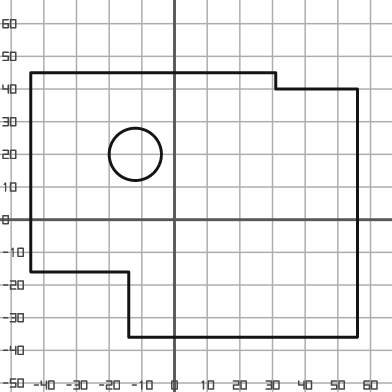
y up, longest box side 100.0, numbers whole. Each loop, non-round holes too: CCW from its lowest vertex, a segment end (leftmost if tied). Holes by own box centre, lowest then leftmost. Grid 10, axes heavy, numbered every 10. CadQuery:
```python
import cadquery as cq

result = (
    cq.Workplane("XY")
    .moveTo(-14.0, -36.0)
    .lineTo(56.0, -36.0)
    .lineTo(56.0, 40.0)
    .lineTo(31.0, 40.0)
    .lineTo(31.0, 45.0)
    .lineTo(-44.0, 45.0)
    .lineTo(-44.0, -16.0)
    .lineTo(-14.0, -16.0)
    .close()
    .moveTo(-12.0, 20.0)
    .circle(8.0)
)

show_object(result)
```